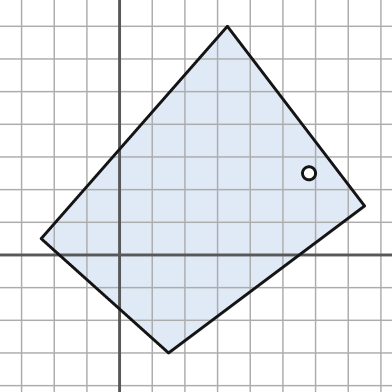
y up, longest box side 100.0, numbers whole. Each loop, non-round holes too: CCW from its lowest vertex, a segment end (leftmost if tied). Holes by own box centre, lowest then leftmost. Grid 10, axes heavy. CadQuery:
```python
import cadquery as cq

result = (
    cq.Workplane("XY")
    .moveTo(15.0, -30.0)
    .lineTo(75.0, 15.0)
    .lineTo(33.0, 70.0)
    .lineTo(-24.0, 5.0)
    .close()
    .moveTo(58.0, 25.0)
    .circle(2.0)
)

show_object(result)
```